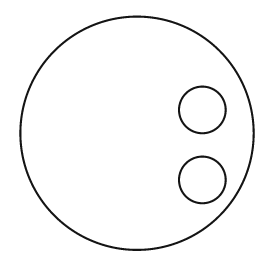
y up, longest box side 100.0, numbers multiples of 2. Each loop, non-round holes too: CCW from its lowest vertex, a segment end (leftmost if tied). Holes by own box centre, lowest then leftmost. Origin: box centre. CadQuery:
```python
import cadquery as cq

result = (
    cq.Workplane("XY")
    .moveTo(0.0, 0.0)
    .circle(50.0)
    .moveTo(28.0, -20.0)
    .circle(10.0)
    .moveTo(28.0, 10.0)
    .circle(10.0)
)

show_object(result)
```